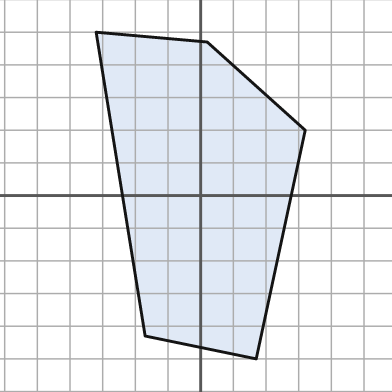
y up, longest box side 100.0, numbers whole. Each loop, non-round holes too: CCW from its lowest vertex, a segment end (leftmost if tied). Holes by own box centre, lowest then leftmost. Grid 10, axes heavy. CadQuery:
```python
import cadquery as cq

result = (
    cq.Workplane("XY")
    .moveTo(17.0, -50.0)
    .lineTo(32.0, 20.0)
    .lineTo(2.0, 47.0)
    .lineTo(-32.0, 50.0)
    .lineTo(-17.0, -43.0)
    .close()
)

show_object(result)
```